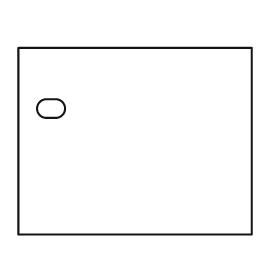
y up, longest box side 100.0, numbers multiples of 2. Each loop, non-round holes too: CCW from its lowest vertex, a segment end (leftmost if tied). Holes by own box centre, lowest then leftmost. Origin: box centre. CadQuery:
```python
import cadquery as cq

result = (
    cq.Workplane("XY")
    .moveTo(-50.0, -40.0)
    .lineTo(50.0, -40.0)
    .lineTo(50.0, 40.0)
    .lineTo(-50.0, 40.0)
    .close()
    .moveTo(-38.0, 10.0)
    .lineTo(-34.0, 10.0)
    .threePointArc((-30.0, 14.0), (-34.0, 18.0))
    .lineTo(-38.0, 18.0)
    .threePointArc((-42.0, 14.0), (-38.0, 10.0))
    .close()
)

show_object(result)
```